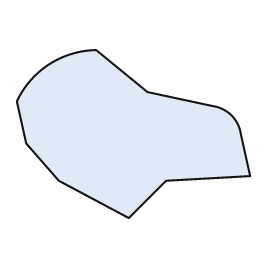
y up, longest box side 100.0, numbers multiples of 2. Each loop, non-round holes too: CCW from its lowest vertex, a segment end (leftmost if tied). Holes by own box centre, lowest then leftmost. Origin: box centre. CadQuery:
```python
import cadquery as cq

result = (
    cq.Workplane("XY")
    .moveTo(-2.0, -36.0)
    .lineTo(14.0, -20.0)
    .lineTo(50.0, -18.0)
    .lineTo(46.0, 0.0)
    .threePointArc((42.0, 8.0), (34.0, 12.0))
    .lineTo(6.0, 18.0)
    .lineTo(-16.0, 36.0)
    .threePointArc((-36.0, 30.0), (-50.0, 14.0))
    .lineTo(-46.0, -4.0)
    .lineTo(-32.0, -20.0)
    .close()
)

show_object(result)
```